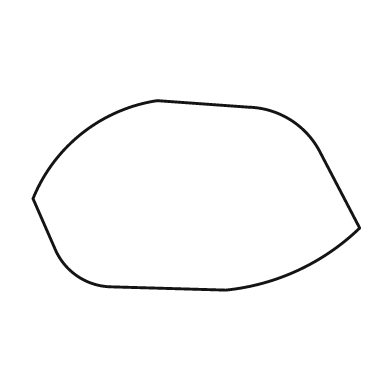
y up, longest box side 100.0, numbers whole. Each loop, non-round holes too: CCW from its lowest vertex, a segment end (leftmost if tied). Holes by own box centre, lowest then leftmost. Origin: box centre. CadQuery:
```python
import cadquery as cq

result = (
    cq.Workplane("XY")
    .moveTo(9.0, -29.0)
    .threePointArc((31.0, -23.0), (50.0, -10.0))
    .lineTo(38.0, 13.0)
    .threePointArc((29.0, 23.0), (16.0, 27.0))
    .lineTo(-12.0, 29.0)
    .threePointArc((-35.0, 19.0), (-50.0, -1.0))
    .lineTo(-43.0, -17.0)
    .threePointArc((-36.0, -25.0), (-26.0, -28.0))
    .close()
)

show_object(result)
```